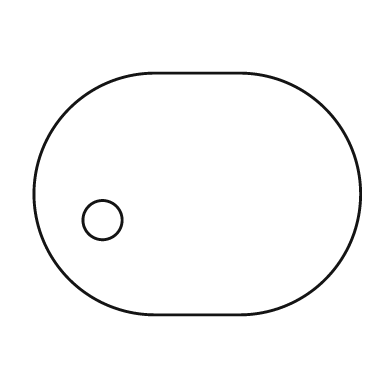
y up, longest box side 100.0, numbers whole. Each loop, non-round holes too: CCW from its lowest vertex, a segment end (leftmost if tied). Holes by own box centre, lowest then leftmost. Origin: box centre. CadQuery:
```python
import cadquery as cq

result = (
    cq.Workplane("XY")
    .moveTo(-13.0, -37.0)
    .lineTo(13.0, -37.0)
    .threePointArc((50.0, 0.0), (13.0, 37.0))
    .lineTo(-13.0, 37.0)
    .threePointArc((-50.0, 0.0), (-13.0, -37.0))
    .close()
    .moveTo(-29.0, -8.0)
    .circle(6.0)
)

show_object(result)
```